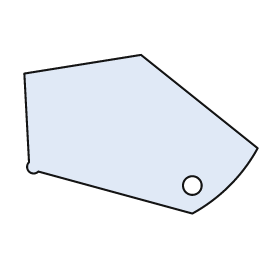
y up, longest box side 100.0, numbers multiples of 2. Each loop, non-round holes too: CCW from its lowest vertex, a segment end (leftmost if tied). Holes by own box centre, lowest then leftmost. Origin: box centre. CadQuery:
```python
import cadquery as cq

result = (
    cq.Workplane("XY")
    .moveTo(22.0, -34.0)
    .threePointArc((38.0, -22.0), (50.0, -6.0))
    .lineTo(0.0, 34.0)
    .lineTo(-50.0, 26.0)
    .lineTo(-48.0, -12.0)
    .threePointArc((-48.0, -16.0), (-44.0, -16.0))
    .close()
    .moveTo(22.0, -22.0)
    .circle(4.0)
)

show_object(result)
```